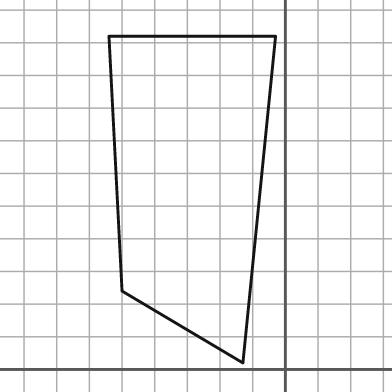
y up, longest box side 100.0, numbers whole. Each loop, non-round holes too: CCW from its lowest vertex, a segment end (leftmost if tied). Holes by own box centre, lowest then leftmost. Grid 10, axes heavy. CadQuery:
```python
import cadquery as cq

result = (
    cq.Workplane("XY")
    .moveTo(-13.0, 2.0)
    .lineTo(-3.0, 102.0)
    .lineTo(-54.0, 102.0)
    .lineTo(-50.0, 24.0)
    .close()
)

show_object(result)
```